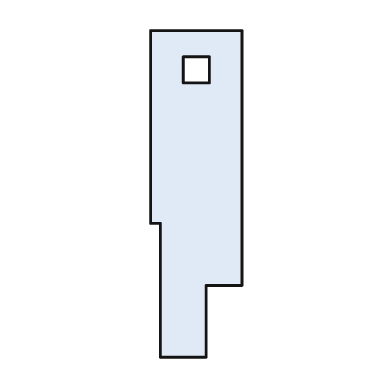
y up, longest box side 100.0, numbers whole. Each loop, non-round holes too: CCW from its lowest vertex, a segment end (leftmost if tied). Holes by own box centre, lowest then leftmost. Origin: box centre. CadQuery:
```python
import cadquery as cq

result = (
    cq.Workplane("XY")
    .moveTo(-11.0, -50.0)
    .lineTo(3.0, -50.0)
    .lineTo(3.0, -28.0)
    .lineTo(14.0, -28.0)
    .lineTo(14.0, 50.0)
    .lineTo(-14.0, 50.0)
    .lineTo(-14.0, -9.0)
    .lineTo(-11.0, -9.0)
    .close()
    .moveTo(-4.0, 34.0)
    .lineTo(4.0, 34.0)
    .lineTo(4.0, 42.0)
    .lineTo(-4.0, 42.0)
    .close()
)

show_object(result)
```